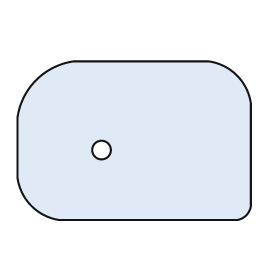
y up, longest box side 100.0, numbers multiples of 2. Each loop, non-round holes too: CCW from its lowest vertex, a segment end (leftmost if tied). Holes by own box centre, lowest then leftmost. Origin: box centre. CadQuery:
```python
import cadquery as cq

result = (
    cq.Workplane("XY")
    .moveTo(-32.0, -34.0)
    .lineTo(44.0, -34.0)
    .threePointArc((48.0, -32.0), (50.0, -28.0))
    .lineTo(50.0, 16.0)
    .threePointArc((44.0, 28.0), (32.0, 34.0))
    .lineTo(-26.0, 34.0)
    .threePointArc((-42.0, 26.0), (-50.0, 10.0))
    .lineTo(-50.0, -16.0)
    .threePointArc((-44.0, -28.0), (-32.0, -34.0))
    .close()
    .moveTo(-14.0, -4.0)
    .circle(4.0)
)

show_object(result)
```